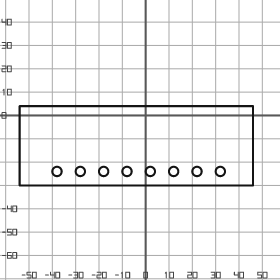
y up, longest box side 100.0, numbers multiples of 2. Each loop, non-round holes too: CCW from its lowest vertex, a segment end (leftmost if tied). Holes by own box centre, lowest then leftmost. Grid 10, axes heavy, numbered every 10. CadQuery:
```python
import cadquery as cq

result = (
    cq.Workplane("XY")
    .moveTo(-54.0, -30.0)
    .lineTo(46.0, -30.0)
    .lineTo(46.0, 4.0)
    .lineTo(-54.0, 4.0)
    .close()
    .moveTo(-38.0, -24.0)
    .circle(2.0)
    .moveTo(-28.0, -24.0)
    .circle(2.0)
    .moveTo(-18.0, -24.0)
    .circle(2.0)
    .moveTo(-8.0, -24.0)
    .circle(2.0)
    .moveTo(2.0, -24.0)
    .circle(2.0)
    .moveTo(12.0, -24.0)
    .circle(2.0)
    .moveTo(22.0, -24.0)
    .circle(2.0)
    .moveTo(32.0, -24.0)
    .circle(2.0)
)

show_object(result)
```